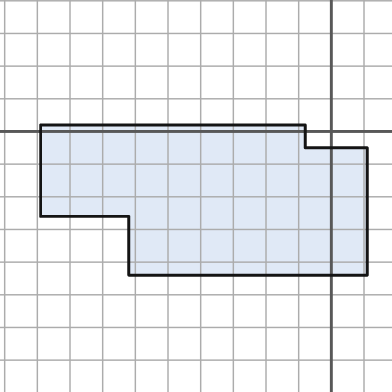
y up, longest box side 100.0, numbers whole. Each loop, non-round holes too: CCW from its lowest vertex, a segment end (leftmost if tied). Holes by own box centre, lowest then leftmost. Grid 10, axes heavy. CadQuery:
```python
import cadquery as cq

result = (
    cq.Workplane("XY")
    .moveTo(-62.0, -44.0)
    .lineTo(11.0, -44.0)
    .lineTo(11.0, -5.0)
    .lineTo(-8.0, -5.0)
    .lineTo(-8.0, 2.0)
    .lineTo(-89.0, 2.0)
    .lineTo(-89.0, -26.0)
    .lineTo(-62.0, -26.0)
    .close()
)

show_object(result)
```